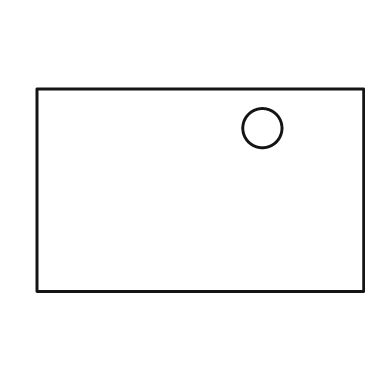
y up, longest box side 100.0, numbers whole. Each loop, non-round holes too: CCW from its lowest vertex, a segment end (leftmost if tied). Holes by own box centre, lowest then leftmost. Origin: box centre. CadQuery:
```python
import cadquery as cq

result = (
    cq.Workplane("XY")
    .moveTo(-50.0, -31.0)
    .lineTo(50.0, -31.0)
    .lineTo(50.0, 31.0)
    .lineTo(-50.0, 31.0)
    .close()
    .moveTo(19.0, 19.0)
    .circle(6.0)
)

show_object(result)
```